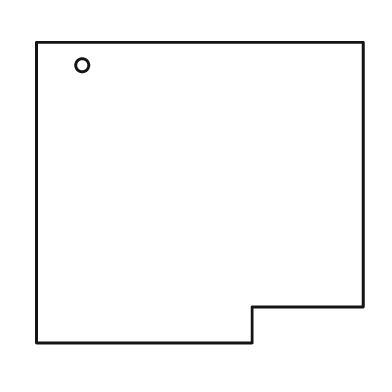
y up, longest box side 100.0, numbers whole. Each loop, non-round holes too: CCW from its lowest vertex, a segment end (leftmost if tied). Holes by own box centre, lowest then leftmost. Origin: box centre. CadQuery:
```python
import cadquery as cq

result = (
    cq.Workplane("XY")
    .moveTo(-50.0, -46.0)
    .lineTo(16.0, -46.0)
    .lineTo(16.0, -35.0)
    .lineTo(50.0, -35.0)
    .lineTo(50.0, 46.0)
    .lineTo(-50.0, 46.0)
    .close()
    .moveTo(-36.0, 39.0)
    .circle(2.0)
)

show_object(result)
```